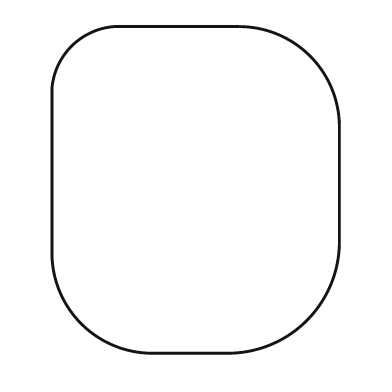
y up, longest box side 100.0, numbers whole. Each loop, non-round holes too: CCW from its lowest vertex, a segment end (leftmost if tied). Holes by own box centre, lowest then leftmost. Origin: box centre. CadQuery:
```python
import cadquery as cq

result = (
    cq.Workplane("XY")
    .moveTo(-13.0, -50.0)
    .lineTo(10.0, -50.0)
    .threePointArc((34.0, -40.0), (44.0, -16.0))
    .lineTo(44.0, 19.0)
    .threePointArc((35.0, 41.0), (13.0, 50.0))
    .lineTo(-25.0, 50.0)
    .threePointArc((-38.0, 44.0), (-44.0, 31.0))
    .lineTo(-44.0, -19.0)
    .threePointArc((-35.0, -41.0), (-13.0, -50.0))
    .close()
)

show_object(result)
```